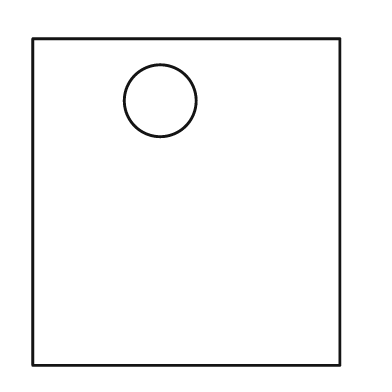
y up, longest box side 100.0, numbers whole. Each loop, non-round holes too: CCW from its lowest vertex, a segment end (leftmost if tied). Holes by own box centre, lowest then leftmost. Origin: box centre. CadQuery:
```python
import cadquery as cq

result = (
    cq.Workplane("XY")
    .moveTo(-47.0, -50.0)
    .lineTo(47.0, -50.0)
    .lineTo(47.0, 50.0)
    .lineTo(-47.0, 50.0)
    .close()
    .moveTo(-8.0, 31.0)
    .circle(11.0)
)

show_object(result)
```